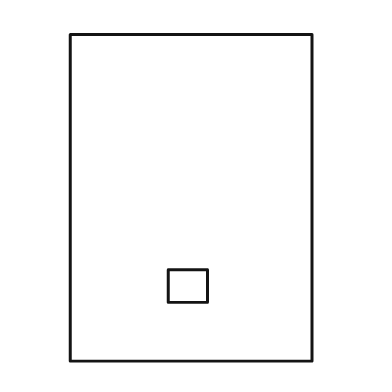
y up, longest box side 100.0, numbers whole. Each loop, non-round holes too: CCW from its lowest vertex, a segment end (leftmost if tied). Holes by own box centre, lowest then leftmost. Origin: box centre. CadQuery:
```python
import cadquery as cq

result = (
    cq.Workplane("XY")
    .moveTo(-37.0, -50.0)
    .lineTo(37.0, -50.0)
    .lineTo(37.0, 50.0)
    .lineTo(-37.0, 50.0)
    .close()
    .moveTo(-7.0, -32.0)
    .lineTo(5.0, -32.0)
    .lineTo(5.0, -22.0)
    .lineTo(-7.0, -22.0)
    .close()
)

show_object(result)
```